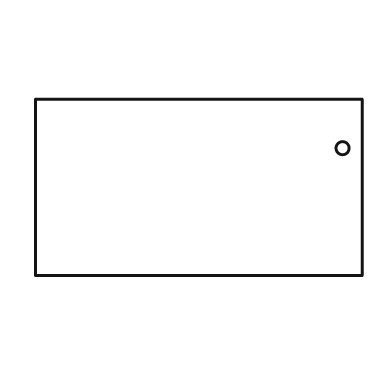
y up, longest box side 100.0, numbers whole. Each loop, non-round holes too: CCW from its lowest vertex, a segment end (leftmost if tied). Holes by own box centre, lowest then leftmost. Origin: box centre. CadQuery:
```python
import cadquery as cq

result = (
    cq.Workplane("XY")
    .moveTo(-50.0, -27.0)
    .lineTo(50.0, -27.0)
    .lineTo(50.0, 27.0)
    .lineTo(-50.0, 27.0)
    .close()
    .moveTo(44.0, 12.0)
    .circle(2.0)
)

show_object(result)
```